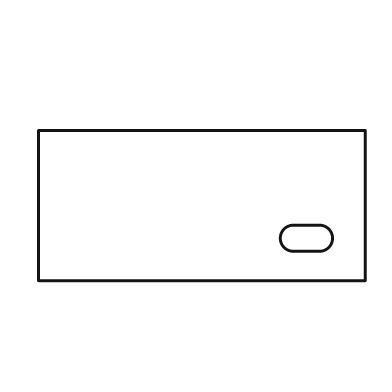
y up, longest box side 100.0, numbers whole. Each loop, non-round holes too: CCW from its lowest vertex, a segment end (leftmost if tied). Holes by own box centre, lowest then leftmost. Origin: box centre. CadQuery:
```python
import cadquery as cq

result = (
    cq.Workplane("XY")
    .moveTo(-50.0, -23.0)
    .lineTo(50.0, -23.0)
    .lineTo(50.0, 23.0)
    .lineTo(-50.0, 23.0)
    .close()
    .moveTo(28.0, -14.0)
    .lineTo(36.0, -14.0)
    .threePointArc((40.0, -10.0), (36.0, -6.0))
    .lineTo(28.0, -6.0)
    .threePointArc((24.0, -10.0), (28.0, -14.0))
    .close()
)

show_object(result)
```